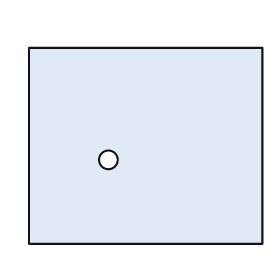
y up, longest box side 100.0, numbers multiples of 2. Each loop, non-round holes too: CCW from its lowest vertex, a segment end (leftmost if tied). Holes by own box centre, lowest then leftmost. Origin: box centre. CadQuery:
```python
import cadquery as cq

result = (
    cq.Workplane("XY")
    .moveTo(-50.0, -42.0)
    .lineTo(50.0, -42.0)
    .lineTo(50.0, 42.0)
    .lineTo(-50.0, 42.0)
    .close()
    .moveTo(-16.0, -6.0)
    .circle(4.0)
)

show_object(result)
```